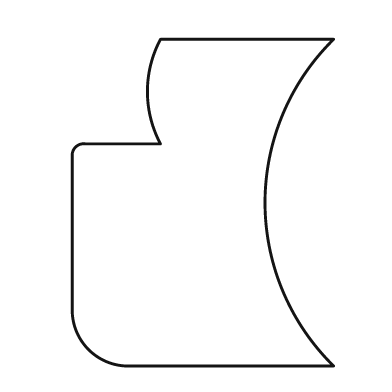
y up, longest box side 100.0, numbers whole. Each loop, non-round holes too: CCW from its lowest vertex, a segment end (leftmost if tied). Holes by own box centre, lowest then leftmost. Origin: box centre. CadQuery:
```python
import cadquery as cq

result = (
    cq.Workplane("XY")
    .moveTo(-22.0, -50.0)
    .lineTo(40.0, -50.0)
    .threePointArc((19.0, 0.0), (40.0, 50.0))
    .lineTo(-13.0, 50.0)
    .threePointArc((-17.0, 34.0), (-13.0, 18.0))
    .lineTo(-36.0, 18.0)
    .threePointArc((-39.0, 17.0), (-40.0, 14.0))
    .lineTo(-40.0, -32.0)
    .threePointArc((-35.0, -45.0), (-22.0, -50.0))
    .close()
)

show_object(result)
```